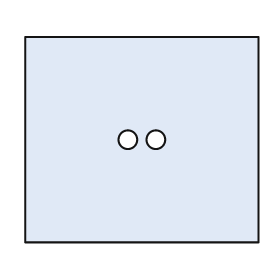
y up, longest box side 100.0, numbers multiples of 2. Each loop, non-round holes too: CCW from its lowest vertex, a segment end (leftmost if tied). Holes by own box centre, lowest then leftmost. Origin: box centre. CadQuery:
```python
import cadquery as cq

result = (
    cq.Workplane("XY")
    .moveTo(-50.0, -44.0)
    .lineTo(50.0, -44.0)
    .lineTo(50.0, 44.0)
    .lineTo(-50.0, 44.0)
    .close()
    .moveTo(-6.0, 0.0)
    .circle(4.0)
    .moveTo(6.0, 0.0)
    .circle(4.0)
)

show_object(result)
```